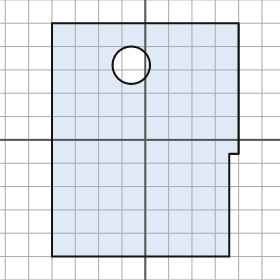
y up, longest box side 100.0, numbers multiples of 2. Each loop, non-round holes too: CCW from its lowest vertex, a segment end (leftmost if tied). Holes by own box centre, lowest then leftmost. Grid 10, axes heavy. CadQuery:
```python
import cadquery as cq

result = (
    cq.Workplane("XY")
    .moveTo(-40.0, -50.0)
    .lineTo(36.0, -50.0)
    .lineTo(36.0, -6.0)
    .lineTo(40.0, -6.0)
    .lineTo(40.0, 50.0)
    .lineTo(-40.0, 50.0)
    .close()
    .moveTo(-6.0, 32.0)
    .circle(8.0)
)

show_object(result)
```